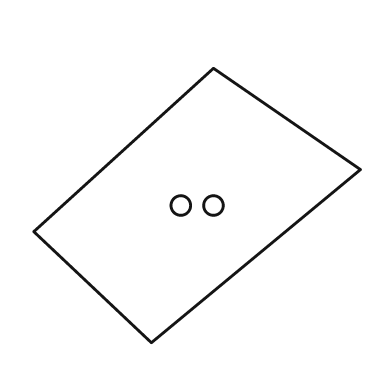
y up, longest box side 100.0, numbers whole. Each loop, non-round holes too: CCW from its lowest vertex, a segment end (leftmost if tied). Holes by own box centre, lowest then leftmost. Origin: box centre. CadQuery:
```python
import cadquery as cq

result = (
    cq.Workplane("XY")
    .moveTo(-14.0, -42.0)
    .lineTo(50.0, 11.0)
    .lineTo(5.0, 42.0)
    .lineTo(-50.0, -8.0)
    .close()
    .moveTo(-5.0, 0.0)
    .circle(3.0)
    .moveTo(5.0, 0.0)
    .circle(3.0)
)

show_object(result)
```